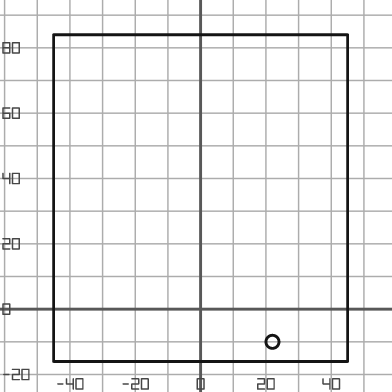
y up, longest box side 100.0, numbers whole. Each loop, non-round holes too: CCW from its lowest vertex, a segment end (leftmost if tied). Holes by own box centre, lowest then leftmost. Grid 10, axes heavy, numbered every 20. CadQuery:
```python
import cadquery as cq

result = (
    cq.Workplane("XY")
    .moveTo(-45.0, -16.0)
    .lineTo(45.0, -16.0)
    .lineTo(45.0, 84.0)
    .lineTo(-45.0, 84.0)
    .close()
    .moveTo(22.0, -10.0)
    .circle(2.0)
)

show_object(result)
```